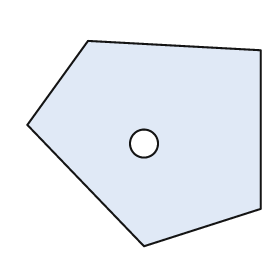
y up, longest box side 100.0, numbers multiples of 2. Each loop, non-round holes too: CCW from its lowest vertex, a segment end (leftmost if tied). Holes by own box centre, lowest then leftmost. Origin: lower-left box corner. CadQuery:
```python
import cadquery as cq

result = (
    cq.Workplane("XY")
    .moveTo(50.0, 0.0)
    .lineTo(100.0, 16.0)
    .lineTo(100.0, 84.0)
    .lineTo(26.0, 88.0)
    .lineTo(0.0, 52.0)
    .close()
    .moveTo(50.0, 44.0)
    .circle(6.0)
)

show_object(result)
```